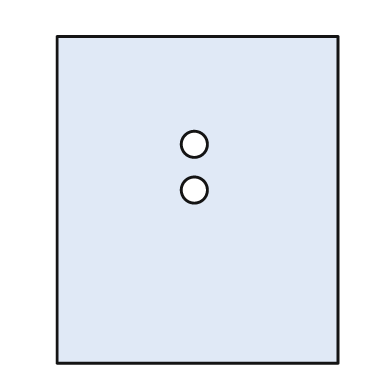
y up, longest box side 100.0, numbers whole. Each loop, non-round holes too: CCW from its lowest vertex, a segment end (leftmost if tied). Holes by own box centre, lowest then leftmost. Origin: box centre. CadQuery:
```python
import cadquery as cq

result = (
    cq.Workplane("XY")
    .moveTo(-43.0, -50.0)
    .lineTo(43.0, -50.0)
    .lineTo(43.0, 50.0)
    .lineTo(-43.0, 50.0)
    .close()
    .moveTo(-1.0, 3.0)
    .circle(4.0)
    .moveTo(-1.0, 17.0)
    .circle(4.0)
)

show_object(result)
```